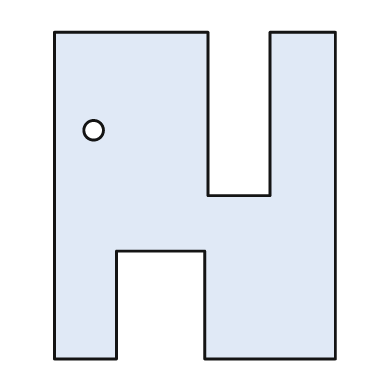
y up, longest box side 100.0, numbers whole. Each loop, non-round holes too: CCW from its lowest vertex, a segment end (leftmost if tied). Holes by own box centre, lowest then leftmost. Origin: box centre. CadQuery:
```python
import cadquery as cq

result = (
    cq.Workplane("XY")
    .moveTo(-43.0, -50.0)
    .lineTo(-24.0, -50.0)
    .lineTo(-24.0, -17.0)
    .lineTo(3.0, -17.0)
    .lineTo(3.0, -50.0)
    .lineTo(43.0, -50.0)
    .lineTo(43.0, 50.0)
    .lineTo(23.0, 50.0)
    .lineTo(23.0, 0.0)
    .lineTo(4.0, 0.0)
    .lineTo(4.0, 50.0)
    .lineTo(-43.0, 50.0)
    .close()
    .moveTo(-31.0, 20.0)
    .circle(3.0)
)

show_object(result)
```